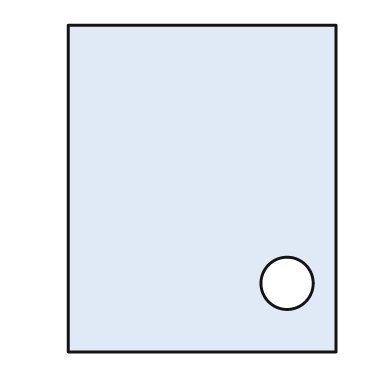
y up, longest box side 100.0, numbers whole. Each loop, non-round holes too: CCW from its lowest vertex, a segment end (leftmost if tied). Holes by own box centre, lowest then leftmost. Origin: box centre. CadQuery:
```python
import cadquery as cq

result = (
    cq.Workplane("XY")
    .moveTo(-41.0, -50.0)
    .lineTo(41.0, -50.0)
    .lineTo(41.0, 50.0)
    .lineTo(-41.0, 50.0)
    .close()
    .moveTo(26.0, -29.0)
    .circle(8.0)
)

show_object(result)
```